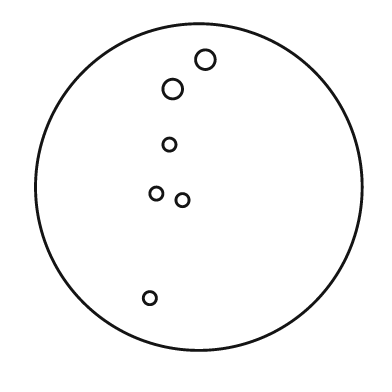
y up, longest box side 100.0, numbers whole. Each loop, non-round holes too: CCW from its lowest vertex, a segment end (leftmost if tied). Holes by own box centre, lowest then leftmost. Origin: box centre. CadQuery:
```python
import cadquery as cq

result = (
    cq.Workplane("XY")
    .moveTo(0.0, 0.0)
    .circle(50.0)
    .moveTo(-15.0, -34.0)
    .circle(2.0)
    .moveTo(-5.0, -4.0)
    .circle(2.0)
    .moveTo(-13.0, -2.0)
    .circle(2.0)
    .moveTo(-9.0, 13.0)
    .circle(2.0)
    .moveTo(-8.0, 30.0)
    .circle(3.0)
    .moveTo(2.0, 39.0)
    .circle(3.0)
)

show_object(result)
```